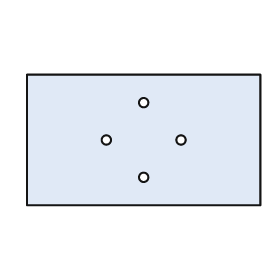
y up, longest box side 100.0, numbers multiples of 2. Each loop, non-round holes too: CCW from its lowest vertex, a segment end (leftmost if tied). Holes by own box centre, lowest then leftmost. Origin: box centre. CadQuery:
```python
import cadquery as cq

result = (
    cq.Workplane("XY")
    .moveTo(-50.0, -28.0)
    .lineTo(50.0, -28.0)
    .lineTo(50.0, 28.0)
    .lineTo(-50.0, 28.0)
    .close()
    .moveTo(0.0, -16.0)
    .circle(2.0)
    .moveTo(-16.0, 0.0)
    .circle(2.0)
    .moveTo(16.0, 0.0)
    .circle(2.0)
    .moveTo(0.0, 16.0)
    .circle(2.0)
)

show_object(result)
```